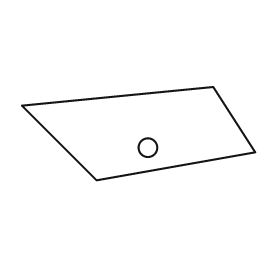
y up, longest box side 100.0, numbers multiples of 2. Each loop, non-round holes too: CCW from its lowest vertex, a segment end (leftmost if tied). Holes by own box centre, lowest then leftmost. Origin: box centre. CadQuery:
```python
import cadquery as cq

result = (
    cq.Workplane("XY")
    .moveTo(-18.0, -20.0)
    .lineTo(50.0, -8.0)
    .lineTo(32.0, 20.0)
    .lineTo(-50.0, 12.0)
    .close()
    .moveTo(4.0, -6.0)
    .circle(4.0)
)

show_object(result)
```